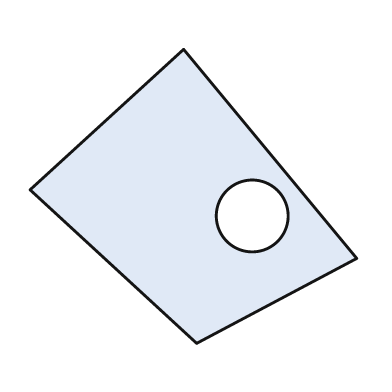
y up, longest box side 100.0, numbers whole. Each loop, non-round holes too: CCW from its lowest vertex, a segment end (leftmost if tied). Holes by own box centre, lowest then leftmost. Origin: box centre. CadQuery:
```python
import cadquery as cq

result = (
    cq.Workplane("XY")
    .moveTo(1.0, -45.0)
    .lineTo(50.0, -19.0)
    .lineTo(-3.0, 45.0)
    .lineTo(-50.0, 2.0)
    .close()
    .moveTo(18.0, -6.0)
    .circle(11.0)
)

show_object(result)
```